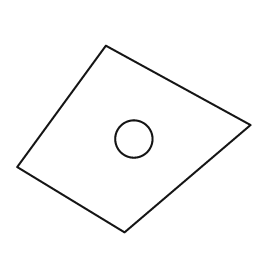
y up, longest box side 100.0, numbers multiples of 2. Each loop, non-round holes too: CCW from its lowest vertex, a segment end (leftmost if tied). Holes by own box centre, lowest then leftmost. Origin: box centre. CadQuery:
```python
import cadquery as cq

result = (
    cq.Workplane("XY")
    .moveTo(-4.0, -40.0)
    .lineTo(50.0, 6.0)
    .lineTo(-12.0, 40.0)
    .lineTo(-50.0, -12.0)
    .close()
    .moveTo(0.0, 0.0)
    .circle(8.0)
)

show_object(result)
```